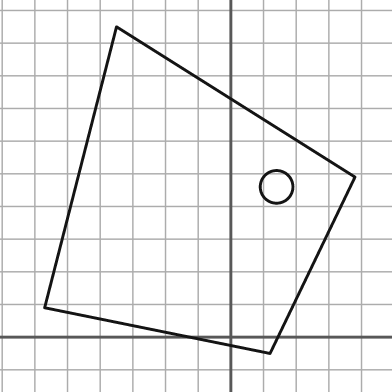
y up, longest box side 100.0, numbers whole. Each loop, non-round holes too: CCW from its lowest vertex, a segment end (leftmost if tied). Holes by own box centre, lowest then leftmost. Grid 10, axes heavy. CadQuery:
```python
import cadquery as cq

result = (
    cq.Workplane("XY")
    .moveTo(12.0, -5.0)
    .lineTo(38.0, 49.0)
    .lineTo(-35.0, 95.0)
    .lineTo(-57.0, 9.0)
    .close()
    .moveTo(14.0, 46.0)
    .circle(5.0)
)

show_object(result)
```